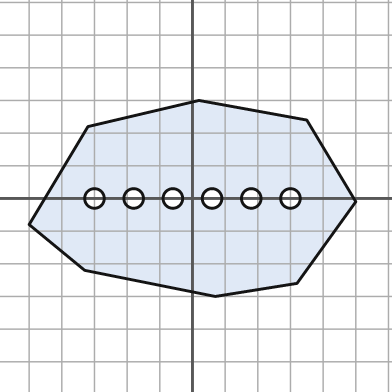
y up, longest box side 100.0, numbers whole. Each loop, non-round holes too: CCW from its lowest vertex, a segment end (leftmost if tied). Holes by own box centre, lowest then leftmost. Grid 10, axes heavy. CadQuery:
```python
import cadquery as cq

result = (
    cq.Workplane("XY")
    .moveTo(7.0, -30.0)
    .lineTo(32.0, -26.0)
    .lineTo(50.0, -1.0)
    .lineTo(35.0, 24.0)
    .lineTo(2.0, 30.0)
    .lineTo(-32.0, 22.0)
    .lineTo(-50.0, -8.0)
    .lineTo(-33.0, -22.0)
    .close()
    .moveTo(-30.0, 0.0)
    .circle(3.0)
    .moveTo(-18.0, 0.0)
    .circle(3.0)
    .moveTo(-6.0, 0.0)
    .circle(3.0)
    .moveTo(6.0, 0.0)
    .circle(3.0)
    .moveTo(18.0, 0.0)
    .circle(3.0)
    .moveTo(30.0, 0.0)
    .circle(3.0)
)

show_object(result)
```